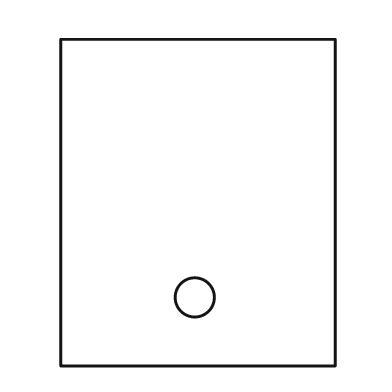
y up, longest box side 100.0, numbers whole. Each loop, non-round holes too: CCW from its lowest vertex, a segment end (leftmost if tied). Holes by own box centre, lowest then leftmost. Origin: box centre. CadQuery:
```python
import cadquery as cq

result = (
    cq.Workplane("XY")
    .moveTo(-42.0, -50.0)
    .lineTo(42.0, -50.0)
    .lineTo(42.0, 50.0)
    .lineTo(-42.0, 50.0)
    .close()
    .moveTo(-1.0, -29.0)
    .circle(6.0)
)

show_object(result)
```